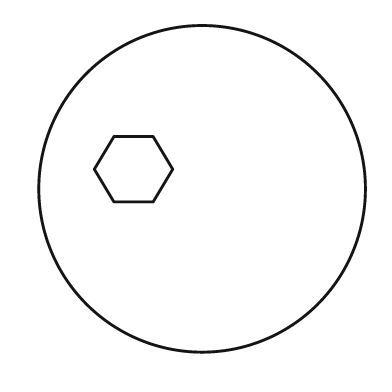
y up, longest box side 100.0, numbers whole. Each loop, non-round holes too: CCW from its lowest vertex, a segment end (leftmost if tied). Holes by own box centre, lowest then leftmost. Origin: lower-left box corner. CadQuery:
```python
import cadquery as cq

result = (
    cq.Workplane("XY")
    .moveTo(50.0, 50.0)
    .circle(50.0)
    .moveTo(23.0, 46.0)
    .lineTo(35.0, 46.0)
    .lineTo(41.0, 56.0)
    .lineTo(35.0, 66.0)
    .lineTo(23.0, 66.0)
    .lineTo(17.0, 56.0)
    .close()
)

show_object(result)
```